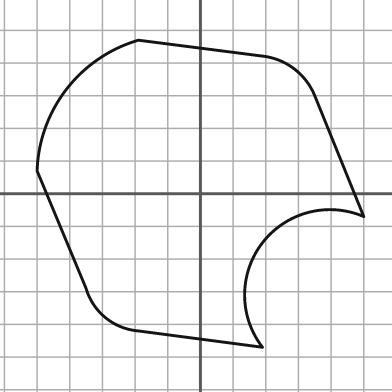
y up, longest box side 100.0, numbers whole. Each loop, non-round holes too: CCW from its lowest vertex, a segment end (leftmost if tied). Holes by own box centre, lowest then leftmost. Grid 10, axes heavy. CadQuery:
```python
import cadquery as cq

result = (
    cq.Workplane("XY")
    .moveTo(19.0, -47.0)
    .threePointArc((19.0, -15.0), (50.0, -7.0))
    .lineTo(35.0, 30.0)
    .threePointArc((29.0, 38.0), (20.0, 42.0))
    .lineTo(-19.0, 47.0)
    .threePointArc((-41.0, 32.0), (-50.0, 7.0))
    .lineTo(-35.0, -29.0)
    .threePointArc((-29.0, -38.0), (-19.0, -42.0))
    .close()
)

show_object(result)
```